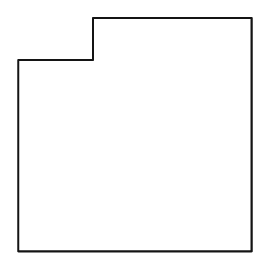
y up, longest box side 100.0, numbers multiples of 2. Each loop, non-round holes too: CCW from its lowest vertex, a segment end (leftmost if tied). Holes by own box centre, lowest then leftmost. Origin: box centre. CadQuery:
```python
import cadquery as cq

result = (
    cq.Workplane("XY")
    .moveTo(-50.0, -50.0)
    .lineTo(50.0, -50.0)
    .lineTo(50.0, 50.0)
    .lineTo(-18.0, 50.0)
    .lineTo(-18.0, 32.0)
    .lineTo(-50.0, 32.0)
    .close()
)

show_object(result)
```